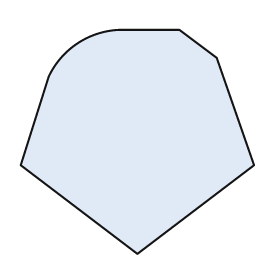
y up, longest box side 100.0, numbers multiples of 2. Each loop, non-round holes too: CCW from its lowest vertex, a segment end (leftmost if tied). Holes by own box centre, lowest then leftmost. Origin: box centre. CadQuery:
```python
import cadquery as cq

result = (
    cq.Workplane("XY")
    .moveTo(0.0, -48.0)
    .lineTo(50.0, -10.0)
    .lineTo(34.0, 36.0)
    .lineTo(18.0, 48.0)
    .lineTo(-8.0, 48.0)
    .threePointArc((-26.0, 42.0), (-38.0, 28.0))
    .lineTo(-50.0, -10.0)
    .close()
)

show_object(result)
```